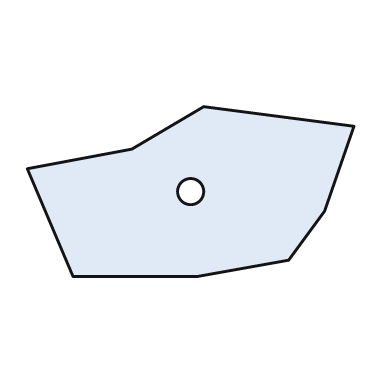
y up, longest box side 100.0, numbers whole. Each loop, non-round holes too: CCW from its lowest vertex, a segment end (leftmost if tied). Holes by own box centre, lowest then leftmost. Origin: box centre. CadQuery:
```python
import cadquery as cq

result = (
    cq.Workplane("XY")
    .moveTo(-36.0, -26.0)
    .lineTo(2.0, -26.0)
    .lineTo(30.0, -21.0)
    .lineTo(41.0, -6.0)
    .lineTo(50.0, 20.0)
    .lineTo(4.0, 26.0)
    .lineTo(-18.0, 13.0)
    .lineTo(-50.0, 7.0)
    .close()
    .moveTo(0.0, 0.0)
    .circle(4.0)
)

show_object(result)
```